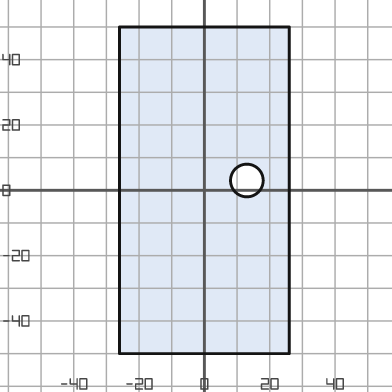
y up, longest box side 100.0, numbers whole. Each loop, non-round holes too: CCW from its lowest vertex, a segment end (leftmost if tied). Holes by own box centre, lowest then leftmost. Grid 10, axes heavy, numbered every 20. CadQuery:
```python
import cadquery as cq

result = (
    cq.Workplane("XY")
    .moveTo(-26.0, -50.0)
    .lineTo(26.0, -50.0)
    .lineTo(26.0, 50.0)
    .lineTo(-26.0, 50.0)
    .close()
    .moveTo(13.0, 3.0)
    .circle(5.0)
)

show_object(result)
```